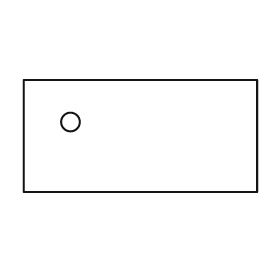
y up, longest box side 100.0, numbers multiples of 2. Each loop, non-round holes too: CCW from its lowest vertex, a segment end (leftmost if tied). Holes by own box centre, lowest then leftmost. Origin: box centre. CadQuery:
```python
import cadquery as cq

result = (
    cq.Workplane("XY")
    .moveTo(-50.0, -24.0)
    .lineTo(50.0, -24.0)
    .lineTo(50.0, 24.0)
    .lineTo(-50.0, 24.0)
    .close()
    .moveTo(-30.0, 6.0)
    .circle(4.0)
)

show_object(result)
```